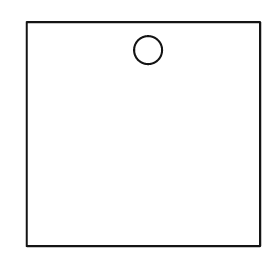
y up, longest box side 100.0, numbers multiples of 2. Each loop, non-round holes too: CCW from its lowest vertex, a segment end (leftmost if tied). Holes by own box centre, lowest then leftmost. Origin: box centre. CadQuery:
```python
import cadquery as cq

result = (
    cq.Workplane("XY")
    .moveTo(-50.0, -48.0)
    .lineTo(50.0, -48.0)
    .lineTo(50.0, 48.0)
    .lineTo(-50.0, 48.0)
    .close()
    .moveTo(2.0, 36.0)
    .circle(6.0)
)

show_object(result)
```